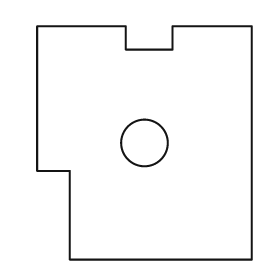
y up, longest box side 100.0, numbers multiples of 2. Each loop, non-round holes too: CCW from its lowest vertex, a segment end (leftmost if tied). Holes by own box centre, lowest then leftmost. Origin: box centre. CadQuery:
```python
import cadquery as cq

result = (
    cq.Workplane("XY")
    .moveTo(-32.0, -50.0)
    .lineTo(46.0, -50.0)
    .lineTo(46.0, 50.0)
    .lineTo(12.0, 50.0)
    .lineTo(12.0, 40.0)
    .lineTo(-8.0, 40.0)
    .lineTo(-8.0, 50.0)
    .lineTo(-46.0, 50.0)
    .lineTo(-46.0, -12.0)
    .lineTo(-32.0, -12.0)
    .close()
    .moveTo(0.0, 0.0)
    .circle(10.0)
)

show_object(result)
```